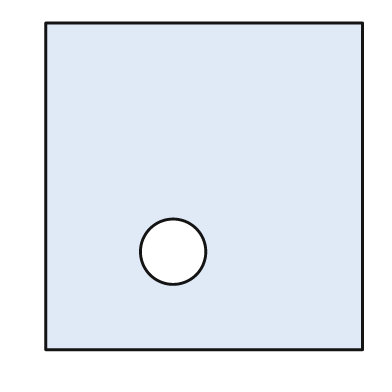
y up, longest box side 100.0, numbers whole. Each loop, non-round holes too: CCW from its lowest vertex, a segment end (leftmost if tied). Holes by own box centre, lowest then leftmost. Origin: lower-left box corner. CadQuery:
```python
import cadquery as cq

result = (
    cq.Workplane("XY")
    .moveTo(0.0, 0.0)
    .lineTo(97.0, 0.0)
    .lineTo(97.0, 100.0)
    .lineTo(0.0, 100.0)
    .close()
    .moveTo(39.0, 30.0)
    .circle(10.0)
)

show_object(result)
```